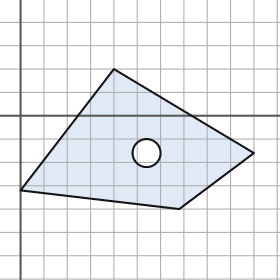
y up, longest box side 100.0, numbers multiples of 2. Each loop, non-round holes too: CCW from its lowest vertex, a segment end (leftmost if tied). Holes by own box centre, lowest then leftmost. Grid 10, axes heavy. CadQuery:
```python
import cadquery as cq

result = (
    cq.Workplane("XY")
    .moveTo(68.0, -40.0)
    .lineTo(100.0, -16.0)
    .lineTo(40.0, 20.0)
    .lineTo(0.0, -32.0)
    .close()
    .moveTo(54.0, -16.0)
    .circle(6.0)
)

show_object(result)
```